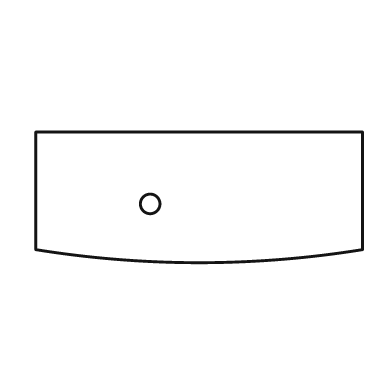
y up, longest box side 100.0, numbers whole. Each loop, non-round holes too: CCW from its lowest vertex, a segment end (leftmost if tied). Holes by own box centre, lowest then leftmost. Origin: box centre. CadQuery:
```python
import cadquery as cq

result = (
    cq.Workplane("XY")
    .moveTo(-50.0, -16.0)
    .threePointArc((0.0, -20.0), (50.0, -16.0))
    .lineTo(50.0, 20.0)
    .lineTo(-50.0, 20.0)
    .close()
    .moveTo(-15.0, -2.0)
    .circle(3.0)
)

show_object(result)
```